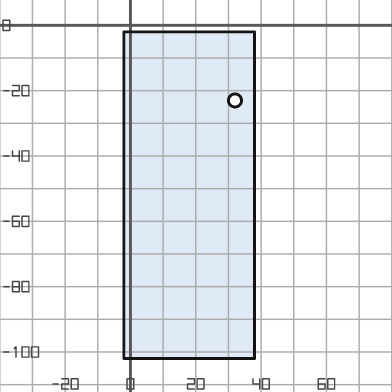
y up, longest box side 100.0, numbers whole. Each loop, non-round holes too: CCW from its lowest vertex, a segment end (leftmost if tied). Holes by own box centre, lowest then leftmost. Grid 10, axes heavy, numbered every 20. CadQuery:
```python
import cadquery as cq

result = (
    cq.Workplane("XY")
    .moveTo(-2.0, -102.0)
    .lineTo(38.0, -102.0)
    .lineTo(38.0, -2.0)
    .lineTo(-2.0, -2.0)
    .close()
    .moveTo(32.0, -23.0)
    .circle(2.0)
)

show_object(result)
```